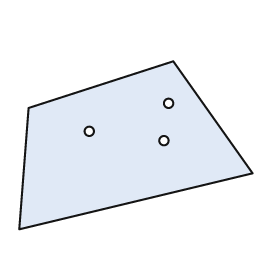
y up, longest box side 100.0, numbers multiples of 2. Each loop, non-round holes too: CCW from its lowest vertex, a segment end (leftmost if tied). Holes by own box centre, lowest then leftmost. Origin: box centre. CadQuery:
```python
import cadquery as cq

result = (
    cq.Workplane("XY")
    .moveTo(-50.0, -36.0)
    .lineTo(50.0, -12.0)
    .lineTo(16.0, 36.0)
    .lineTo(-46.0, 16.0)
    .close()
    .moveTo(12.0, 2.0)
    .circle(2.0)
    .moveTo(-20.0, 6.0)
    .circle(2.0)
    .moveTo(14.0, 18.0)
    .circle(2.0)
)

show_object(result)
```